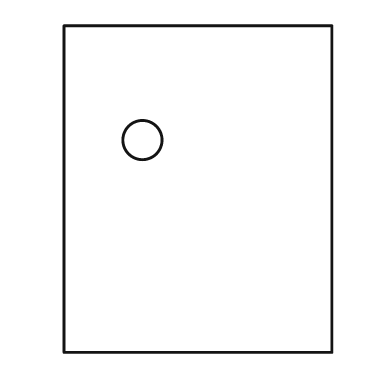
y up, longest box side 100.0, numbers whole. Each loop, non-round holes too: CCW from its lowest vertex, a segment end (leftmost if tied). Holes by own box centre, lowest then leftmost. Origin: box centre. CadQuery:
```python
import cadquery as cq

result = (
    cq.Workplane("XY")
    .moveTo(-41.0, -50.0)
    .lineTo(41.0, -50.0)
    .lineTo(41.0, 50.0)
    .lineTo(-41.0, 50.0)
    .close()
    .moveTo(-17.0, 15.0)
    .circle(6.0)
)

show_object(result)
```